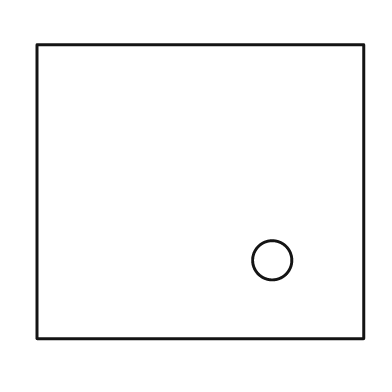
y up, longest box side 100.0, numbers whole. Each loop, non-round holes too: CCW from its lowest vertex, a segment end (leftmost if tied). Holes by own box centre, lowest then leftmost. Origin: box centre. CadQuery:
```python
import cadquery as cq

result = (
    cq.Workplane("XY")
    .moveTo(-50.0, -45.0)
    .lineTo(50.0, -45.0)
    .lineTo(50.0, 45.0)
    .lineTo(-50.0, 45.0)
    .close()
    .moveTo(22.0, -21.0)
    .circle(6.0)
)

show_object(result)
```